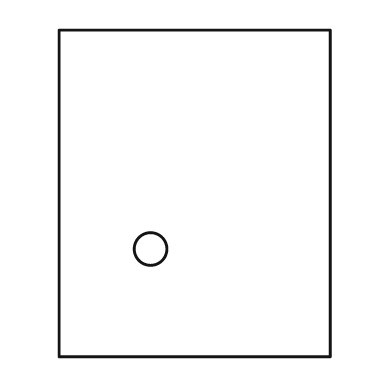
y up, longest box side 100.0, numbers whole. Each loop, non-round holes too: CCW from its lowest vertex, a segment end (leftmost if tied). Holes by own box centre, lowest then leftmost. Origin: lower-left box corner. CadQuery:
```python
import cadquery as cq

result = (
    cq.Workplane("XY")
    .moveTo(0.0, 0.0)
    .lineTo(83.0, 0.0)
    .lineTo(83.0, 100.0)
    .lineTo(0.0, 100.0)
    .close()
    .moveTo(28.0, 33.0)
    .circle(5.0)
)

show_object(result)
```